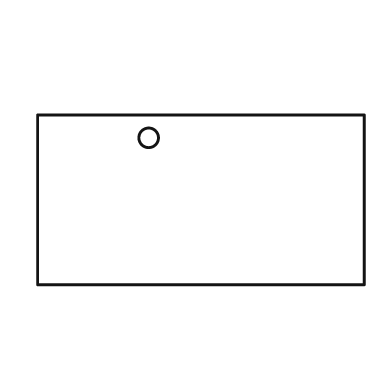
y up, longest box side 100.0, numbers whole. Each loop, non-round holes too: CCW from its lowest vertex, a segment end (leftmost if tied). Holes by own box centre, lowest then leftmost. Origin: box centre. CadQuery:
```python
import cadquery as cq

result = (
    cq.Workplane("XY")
    .moveTo(-50.0, -26.0)
    .lineTo(50.0, -26.0)
    .lineTo(50.0, 26.0)
    .lineTo(-50.0, 26.0)
    .close()
    .moveTo(-16.0, 19.0)
    .circle(3.0)
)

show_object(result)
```